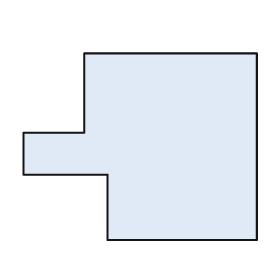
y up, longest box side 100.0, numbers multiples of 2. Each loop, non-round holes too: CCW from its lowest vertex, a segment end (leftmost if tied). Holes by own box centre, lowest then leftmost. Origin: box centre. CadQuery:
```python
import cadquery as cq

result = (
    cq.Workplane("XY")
    .moveTo(-14.0, -40.0)
    .lineTo(50.0, -40.0)
    .lineTo(50.0, 40.0)
    .lineTo(-24.0, 40.0)
    .lineTo(-24.0, 6.0)
    .lineTo(-50.0, 6.0)
    .lineTo(-50.0, -12.0)
    .lineTo(-14.0, -12.0)
    .close()
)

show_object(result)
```